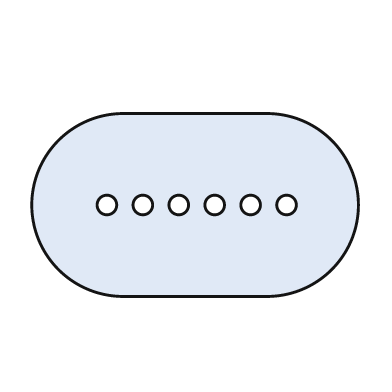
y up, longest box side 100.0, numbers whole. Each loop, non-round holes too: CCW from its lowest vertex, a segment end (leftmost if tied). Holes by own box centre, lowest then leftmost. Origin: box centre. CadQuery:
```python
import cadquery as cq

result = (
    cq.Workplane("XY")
    .moveTo(-22.0, -28.0)
    .lineTo(22.0, -28.0)
    .threePointArc((50.0, 0.0), (22.0, 28.0))
    .lineTo(-22.0, 28.0)
    .threePointArc((-50.0, 0.0), (-22.0, -28.0))
    .close()
    .moveTo(-27.0, 0.0)
    .circle(3.0)
    .moveTo(-16.0, 0.0)
    .circle(3.0)
    .moveTo(-5.0, 0.0)
    .circle(3.0)
    .moveTo(6.0, 0.0)
    .circle(3.0)
    .moveTo(17.0, 0.0)
    .circle(3.0)
    .moveTo(28.0, 0.0)
    .circle(3.0)
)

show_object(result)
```